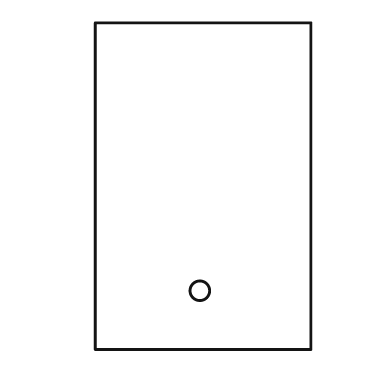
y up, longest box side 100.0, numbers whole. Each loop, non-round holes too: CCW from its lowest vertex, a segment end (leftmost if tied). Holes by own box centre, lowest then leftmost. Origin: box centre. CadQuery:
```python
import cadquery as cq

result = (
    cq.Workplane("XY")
    .moveTo(-33.0, -50.0)
    .lineTo(33.0, -50.0)
    .lineTo(33.0, 50.0)
    .lineTo(-33.0, 50.0)
    .close()
    .moveTo(-1.0, -32.0)
    .circle(3.0)
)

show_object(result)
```